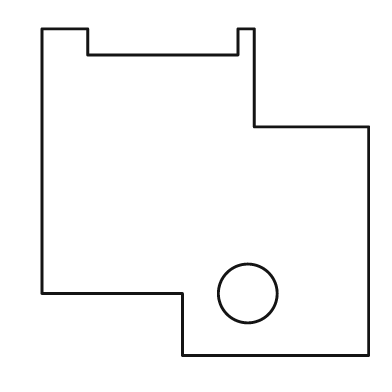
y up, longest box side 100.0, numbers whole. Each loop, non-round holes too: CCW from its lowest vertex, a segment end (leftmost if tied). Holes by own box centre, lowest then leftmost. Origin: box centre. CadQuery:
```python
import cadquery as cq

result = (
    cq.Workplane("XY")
    .moveTo(-7.0, -50.0)
    .lineTo(50.0, -50.0)
    .lineTo(50.0, 20.0)
    .lineTo(15.0, 20.0)
    .lineTo(15.0, 50.0)
    .lineTo(10.0, 50.0)
    .lineTo(10.0, 42.0)
    .lineTo(-36.0, 42.0)
    .lineTo(-36.0, 50.0)
    .lineTo(-50.0, 50.0)
    .lineTo(-50.0, -31.0)
    .lineTo(-7.0, -31.0)
    .close()
    .moveTo(13.0, -31.0)
    .circle(9.0)
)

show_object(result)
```